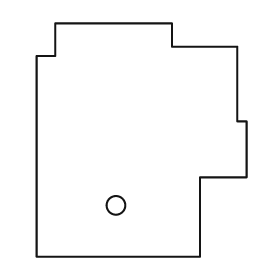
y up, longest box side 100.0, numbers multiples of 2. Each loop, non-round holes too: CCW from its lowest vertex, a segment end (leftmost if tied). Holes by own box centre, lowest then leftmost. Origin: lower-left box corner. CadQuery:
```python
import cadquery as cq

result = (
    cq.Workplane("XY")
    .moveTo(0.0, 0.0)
    .lineTo(70.0, 0.0)
    .lineTo(70.0, 34.0)
    .lineTo(90.0, 34.0)
    .lineTo(90.0, 58.0)
    .lineTo(86.0, 58.0)
    .lineTo(86.0, 90.0)
    .lineTo(58.0, 90.0)
    .lineTo(58.0, 100.0)
    .lineTo(8.0, 100.0)
    .lineTo(8.0, 86.0)
    .lineTo(0.0, 86.0)
    .close()
    .moveTo(34.0, 22.0)
    .circle(4.0)
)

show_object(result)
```